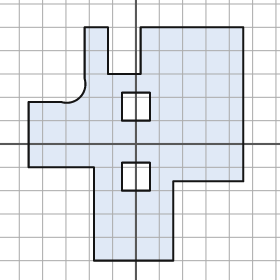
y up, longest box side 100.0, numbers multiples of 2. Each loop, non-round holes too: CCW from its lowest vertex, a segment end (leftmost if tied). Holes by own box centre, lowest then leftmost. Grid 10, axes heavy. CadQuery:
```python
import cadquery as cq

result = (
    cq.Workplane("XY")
    .moveTo(-18.0, -50.0)
    .lineTo(16.0, -50.0)
    .lineTo(16.0, -16.0)
    .lineTo(46.0, -16.0)
    .lineTo(46.0, 50.0)
    .lineTo(2.0, 50.0)
    .lineTo(2.0, 30.0)
    .lineTo(-12.0, 30.0)
    .lineTo(-12.0, 50.0)
    .lineTo(-22.0, 50.0)
    .lineTo(-22.0, 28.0)
    .threePointArc((-24.0, 20.0), (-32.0, 18.0))
    .lineTo(-46.0, 18.0)
    .lineTo(-46.0, -10.0)
    .lineTo(-18.0, -10.0)
    .close()
    .moveTo(-6.0, -20.0)
    .lineTo(6.0, -20.0)
    .lineTo(6.0, -8.0)
    .lineTo(-6.0, -8.0)
    .close()
    .moveTo(-6.0, 10.0)
    .lineTo(6.0, 10.0)
    .lineTo(6.0, 22.0)
    .lineTo(-6.0, 22.0)
    .close()
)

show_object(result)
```